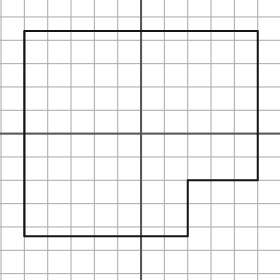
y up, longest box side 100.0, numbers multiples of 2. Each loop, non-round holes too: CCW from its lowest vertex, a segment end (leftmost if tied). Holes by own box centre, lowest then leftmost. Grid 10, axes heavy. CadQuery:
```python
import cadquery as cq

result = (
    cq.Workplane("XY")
    .moveTo(-50.0, -44.0)
    .lineTo(20.0, -44.0)
    .lineTo(20.0, -20.0)
    .lineTo(50.0, -20.0)
    .lineTo(50.0, 44.0)
    .lineTo(-50.0, 44.0)
    .close()
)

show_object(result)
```